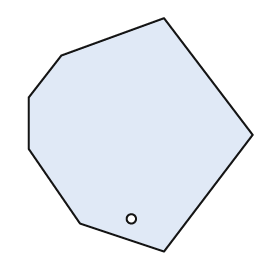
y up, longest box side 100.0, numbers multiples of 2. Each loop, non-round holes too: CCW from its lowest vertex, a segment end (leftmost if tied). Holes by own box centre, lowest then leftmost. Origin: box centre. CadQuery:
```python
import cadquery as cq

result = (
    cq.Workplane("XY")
    .moveTo(10.0, -50.0)
    .lineTo(48.0, 0.0)
    .lineTo(10.0, 50.0)
    .lineTo(-34.0, 34.0)
    .lineTo(-48.0, 16.0)
    .lineTo(-48.0, -6.0)
    .lineTo(-26.0, -38.0)
    .close()
    .moveTo(-4.0, -36.0)
    .circle(2.0)
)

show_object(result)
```